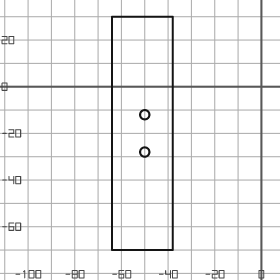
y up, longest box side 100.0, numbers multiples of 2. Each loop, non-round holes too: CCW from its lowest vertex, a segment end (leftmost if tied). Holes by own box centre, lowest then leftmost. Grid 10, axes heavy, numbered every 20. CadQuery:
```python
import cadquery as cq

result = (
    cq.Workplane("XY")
    .moveTo(-64.0, -70.0)
    .lineTo(-38.0, -70.0)
    .lineTo(-38.0, 30.0)
    .lineTo(-64.0, 30.0)
    .close()
    .moveTo(-50.0, -28.0)
    .circle(2.0)
    .moveTo(-50.0, -12.0)
    .circle(2.0)
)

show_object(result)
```